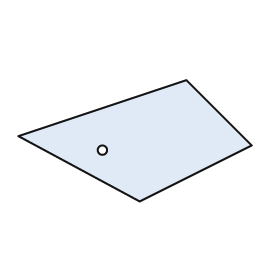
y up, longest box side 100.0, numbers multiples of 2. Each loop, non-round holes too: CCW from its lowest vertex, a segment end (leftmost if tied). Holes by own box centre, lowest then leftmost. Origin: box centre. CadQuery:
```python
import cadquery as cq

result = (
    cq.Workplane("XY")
    .moveTo(2.0, -26.0)
    .lineTo(50.0, -2.0)
    .lineTo(22.0, 26.0)
    .lineTo(-50.0, 2.0)
    .close()
    .moveTo(-14.0, -4.0)
    .circle(2.0)
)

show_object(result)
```